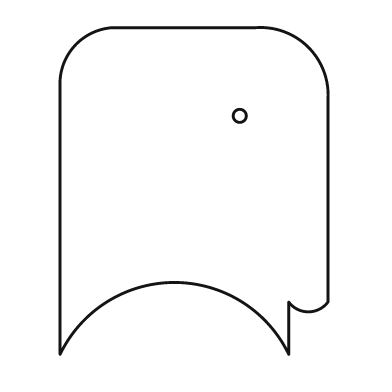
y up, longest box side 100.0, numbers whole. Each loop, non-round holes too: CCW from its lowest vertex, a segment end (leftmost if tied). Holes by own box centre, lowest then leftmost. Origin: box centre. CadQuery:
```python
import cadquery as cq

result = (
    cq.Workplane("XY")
    .moveTo(-41.0, -50.0)
    .threePointArc((-6.0, -28.0), (29.0, -50.0))
    .lineTo(29.0, -34.0)
    .threePointArc((35.0, -37.0), (41.0, -34.0))
    .lineTo(41.0, 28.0)
    .threePointArc((35.0, 44.0), (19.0, 50.0))
    .lineTo(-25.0, 50.0)
    .threePointArc((-36.0, 45.0), (-41.0, 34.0))
    .close()
    .moveTo(14.0, 23.0)
    .circle(2.0)
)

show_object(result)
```